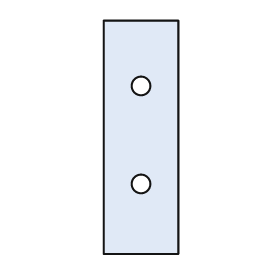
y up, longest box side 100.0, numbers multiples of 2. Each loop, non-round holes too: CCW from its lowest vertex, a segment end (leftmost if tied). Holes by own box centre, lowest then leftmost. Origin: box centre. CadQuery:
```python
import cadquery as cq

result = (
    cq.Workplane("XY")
    .moveTo(-16.0, -50.0)
    .lineTo(16.0, -50.0)
    .lineTo(16.0, 50.0)
    .lineTo(-16.0, 50.0)
    .close()
    .moveTo(0.0, -20.0)
    .circle(4.0)
    .moveTo(0.0, 22.0)
    .circle(4.0)
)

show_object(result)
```